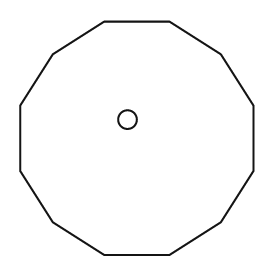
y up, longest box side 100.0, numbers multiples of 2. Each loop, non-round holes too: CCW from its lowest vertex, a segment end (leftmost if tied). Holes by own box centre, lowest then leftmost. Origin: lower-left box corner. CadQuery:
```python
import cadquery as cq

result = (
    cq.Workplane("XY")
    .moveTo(36.0, 0.0)
    .lineTo(64.0, 0.0)
    .lineTo(86.0, 14.0)
    .lineTo(100.0, 36.0)
    .lineTo(100.0, 64.0)
    .lineTo(86.0, 86.0)
    .lineTo(64.0, 100.0)
    .lineTo(36.0, 100.0)
    .lineTo(14.0, 86.0)
    .lineTo(0.0, 64.0)
    .lineTo(0.0, 36.0)
    .lineTo(14.0, 14.0)
    .close()
    .moveTo(46.0, 58.0)
    .circle(4.0)
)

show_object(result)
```